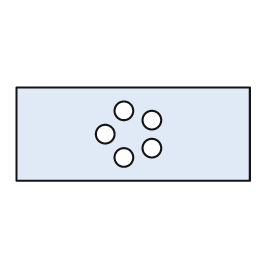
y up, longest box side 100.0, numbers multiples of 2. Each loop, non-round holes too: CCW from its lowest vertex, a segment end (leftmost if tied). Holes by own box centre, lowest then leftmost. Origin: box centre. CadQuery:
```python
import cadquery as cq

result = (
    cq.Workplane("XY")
    .moveTo(-50.0, -20.0)
    .lineTo(50.0, -20.0)
    .lineTo(50.0, 20.0)
    .lineTo(-50.0, 20.0)
    .close()
    .moveTo(-4.0, -10.0)
    .circle(4.0)
    .moveTo(8.0, -6.0)
    .circle(4.0)
    .moveTo(-12.0, 0.0)
    .circle(4.0)
    .moveTo(8.0, 6.0)
    .circle(4.0)
    .moveTo(-4.0, 10.0)
    .circle(4.0)
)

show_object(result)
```